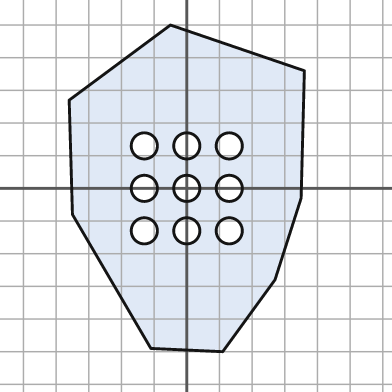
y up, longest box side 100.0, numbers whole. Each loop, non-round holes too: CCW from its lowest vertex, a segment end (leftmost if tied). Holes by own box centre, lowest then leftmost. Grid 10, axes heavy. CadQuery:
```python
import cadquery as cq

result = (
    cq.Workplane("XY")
    .moveTo(11.0, -50.0)
    .lineTo(27.0, -28.0)
    .lineTo(35.0, -3.0)
    .lineTo(36.0, 36.0)
    .lineTo(-5.0, 50.0)
    .lineTo(-36.0, 27.0)
    .lineTo(-35.0, -8.0)
    .lineTo(-11.0, -49.0)
    .close()
    .moveTo(-13.0, -13.0)
    .circle(4.0)
    .moveTo(0.0, -13.0)
    .circle(4.0)
    .moveTo(13.0, -13.0)
    .circle(4.0)
    .moveTo(-13.0, 0.0)
    .circle(4.0)
    .moveTo(0.0, 0.0)
    .circle(4.0)
    .moveTo(13.0, 0.0)
    .circle(4.0)
    .moveTo(-13.0, 13.0)
    .circle(4.0)
    .moveTo(0.0, 13.0)
    .circle(4.0)
    .moveTo(13.0, 13.0)
    .circle(4.0)
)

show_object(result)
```